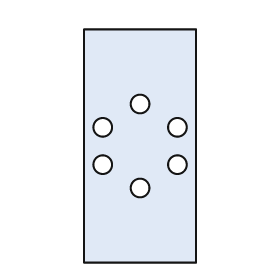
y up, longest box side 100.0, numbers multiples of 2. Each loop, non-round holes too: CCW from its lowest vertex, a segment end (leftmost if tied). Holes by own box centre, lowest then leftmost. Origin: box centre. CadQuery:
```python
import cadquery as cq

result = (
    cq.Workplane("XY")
    .moveTo(-24.0, -50.0)
    .lineTo(24.0, -50.0)
    .lineTo(24.0, 50.0)
    .lineTo(-24.0, 50.0)
    .close()
    .moveTo(0.0, -18.0)
    .circle(4.0)
    .moveTo(-16.0, -8.0)
    .circle(4.0)
    .moveTo(16.0, -8.0)
    .circle(4.0)
    .moveTo(-16.0, 8.0)
    .circle(4.0)
    .moveTo(16.0, 8.0)
    .circle(4.0)
    .moveTo(0.0, 18.0)
    .circle(4.0)
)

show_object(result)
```